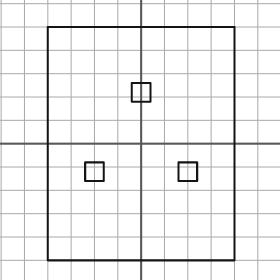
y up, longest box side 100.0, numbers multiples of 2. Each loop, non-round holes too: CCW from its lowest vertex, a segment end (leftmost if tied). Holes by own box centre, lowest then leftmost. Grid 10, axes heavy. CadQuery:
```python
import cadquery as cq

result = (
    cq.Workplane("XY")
    .moveTo(-40.0, -50.0)
    .lineTo(40.0, -50.0)
    .lineTo(40.0, 50.0)
    .lineTo(-40.0, 50.0)
    .close()
    .moveTo(-24.0, -16.0)
    .lineTo(-16.0, -16.0)
    .lineTo(-16.0, -8.0)
    .lineTo(-24.0, -8.0)
    .close()
    .moveTo(16.0, -16.0)
    .lineTo(24.0, -16.0)
    .lineTo(24.0, -8.0)
    .lineTo(16.0, -8.0)
    .close()
    .moveTo(-4.0, 18.0)
    .lineTo(4.0, 18.0)
    .lineTo(4.0, 26.0)
    .lineTo(-4.0, 26.0)
    .close()
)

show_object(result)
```